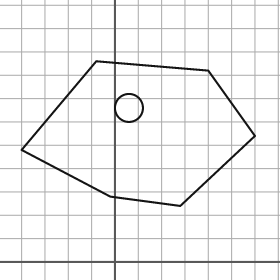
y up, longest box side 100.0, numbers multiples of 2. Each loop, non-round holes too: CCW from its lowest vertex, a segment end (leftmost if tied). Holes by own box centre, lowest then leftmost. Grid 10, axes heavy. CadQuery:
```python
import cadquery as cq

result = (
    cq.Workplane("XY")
    .moveTo(28.0, 24.0)
    .lineTo(60.0, 54.0)
    .lineTo(40.0, 82.0)
    .lineTo(-8.0, 86.0)
    .lineTo(-40.0, 48.0)
    .lineTo(-2.0, 28.0)
    .close()
    .moveTo(6.0, 66.0)
    .circle(6.0)
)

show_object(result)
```